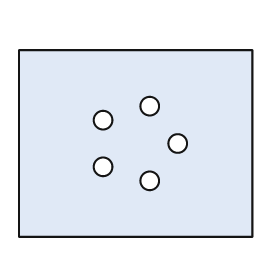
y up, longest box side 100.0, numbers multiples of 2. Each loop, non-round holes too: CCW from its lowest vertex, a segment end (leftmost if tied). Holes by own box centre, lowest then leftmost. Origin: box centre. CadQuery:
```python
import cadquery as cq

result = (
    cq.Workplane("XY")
    .moveTo(-50.0, -40.0)
    .lineTo(50.0, -40.0)
    .lineTo(50.0, 40.0)
    .lineTo(-50.0, 40.0)
    .close()
    .moveTo(6.0, -16.0)
    .circle(4.0)
    .moveTo(-14.0, -10.0)
    .circle(4.0)
    .moveTo(18.0, 0.0)
    .circle(4.0)
    .moveTo(-14.0, 10.0)
    .circle(4.0)
    .moveTo(6.0, 16.0)
    .circle(4.0)
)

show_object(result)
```